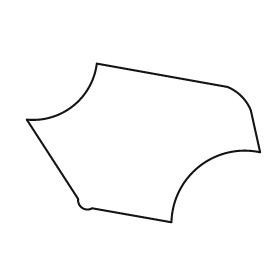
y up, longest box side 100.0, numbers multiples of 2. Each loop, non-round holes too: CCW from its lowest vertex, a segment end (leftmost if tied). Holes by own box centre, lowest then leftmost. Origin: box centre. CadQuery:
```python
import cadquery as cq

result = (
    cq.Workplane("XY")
    .moveTo(12.0, -34.0)
    .threePointArc((24.0, -10.0), (50.0, -4.0))
    .lineTo(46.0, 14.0)
    .threePointArc((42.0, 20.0), (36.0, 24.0))
    .lineTo(-20.0, 34.0)
    .threePointArc((-30.0, 16.0), (-50.0, 10.0))
    .lineTo(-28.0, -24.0)
    .threePointArc((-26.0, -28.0), (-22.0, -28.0))
    .close()
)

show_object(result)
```